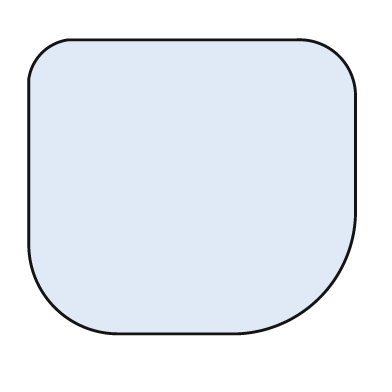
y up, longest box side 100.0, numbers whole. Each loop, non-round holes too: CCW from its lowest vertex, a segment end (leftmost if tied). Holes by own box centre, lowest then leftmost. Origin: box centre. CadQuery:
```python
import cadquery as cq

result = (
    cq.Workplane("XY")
    .moveTo(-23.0, -45.0)
    .lineTo(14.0, -45.0)
    .threePointArc((39.0, -34.0), (50.0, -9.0))
    .lineTo(50.0, 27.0)
    .threePointArc((45.0, 40.0), (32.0, 45.0))
    .lineTo(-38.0, 45.0)
    .threePointArc((-46.0, 41.0), (-50.0, 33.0))
    .lineTo(-50.0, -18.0)
    .threePointArc((-42.0, -37.0), (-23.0, -45.0))
    .close()
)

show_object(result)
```